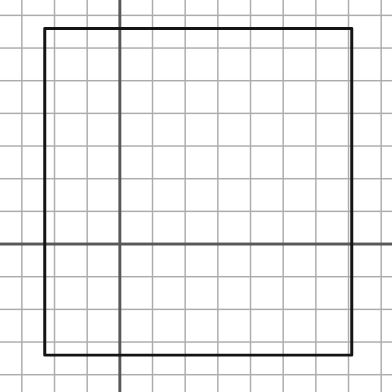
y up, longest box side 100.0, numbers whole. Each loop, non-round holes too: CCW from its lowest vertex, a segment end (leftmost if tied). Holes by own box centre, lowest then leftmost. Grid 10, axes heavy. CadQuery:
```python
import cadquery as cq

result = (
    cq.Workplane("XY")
    .moveTo(-23.0, -34.0)
    .lineTo(71.0, -34.0)
    .lineTo(71.0, 66.0)
    .lineTo(-23.0, 66.0)
    .close()
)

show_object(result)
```